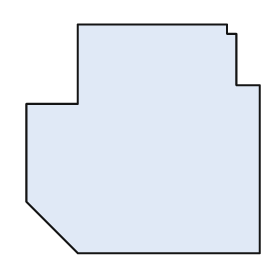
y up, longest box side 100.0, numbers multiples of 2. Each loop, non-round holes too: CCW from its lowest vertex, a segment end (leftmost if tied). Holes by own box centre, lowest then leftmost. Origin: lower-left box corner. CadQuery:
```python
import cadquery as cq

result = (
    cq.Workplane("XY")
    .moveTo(22.0, 0.0)
    .lineTo(100.0, 0.0)
    .lineTo(100.0, 72.0)
    .lineTo(90.0, 72.0)
    .lineTo(90.0, 94.0)
    .lineTo(86.0, 94.0)
    .lineTo(86.0, 98.0)
    .lineTo(22.0, 98.0)
    .lineTo(22.0, 64.0)
    .lineTo(0.0, 64.0)
    .lineTo(0.0, 22.0)
    .close()
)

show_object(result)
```